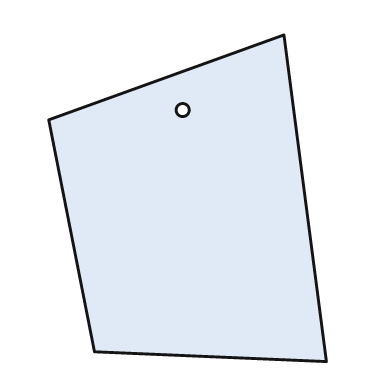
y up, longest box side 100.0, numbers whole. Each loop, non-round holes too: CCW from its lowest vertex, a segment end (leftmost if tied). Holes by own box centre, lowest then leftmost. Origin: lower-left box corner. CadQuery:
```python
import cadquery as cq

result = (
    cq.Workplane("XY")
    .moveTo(85.0, 0.0)
    .lineTo(72.0, 100.0)
    .lineTo(0.0, 74.0)
    .lineTo(14.0, 3.0)
    .close()
    .moveTo(41.0, 77.0)
    .circle(2.0)
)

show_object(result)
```